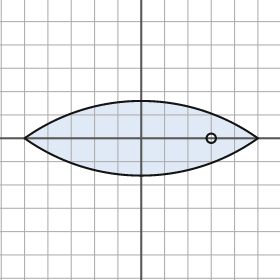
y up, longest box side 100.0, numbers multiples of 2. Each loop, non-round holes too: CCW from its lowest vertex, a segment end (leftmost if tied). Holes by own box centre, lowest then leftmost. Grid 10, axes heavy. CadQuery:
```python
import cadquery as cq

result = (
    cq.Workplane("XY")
    .moveTo(-50.0, 0.0)
    .threePointArc((0.0, -16.0), (50.0, 0.0))
    .threePointArc((0.0, 16.0), (-50.0, 0.0))
    .close()
    .moveTo(30.0, 0.0)
    .circle(2.0)
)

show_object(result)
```